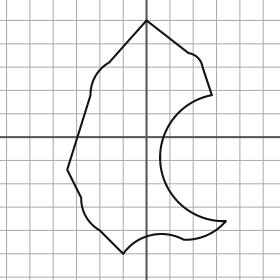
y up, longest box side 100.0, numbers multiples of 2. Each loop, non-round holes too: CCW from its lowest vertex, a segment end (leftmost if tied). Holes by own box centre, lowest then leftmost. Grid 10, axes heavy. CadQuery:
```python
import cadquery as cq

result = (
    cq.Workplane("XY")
    .moveTo(-10.0, -50.0)
    .threePointArc((2.0, -42.0), (16.0, -44.0))
    .threePointArc((26.0, -42.0), (34.0, -36.0))
    .threePointArc((6.0, -12.0), (28.0, 18.0))
    .lineTo(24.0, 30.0)
    .threePointArc((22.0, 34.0), (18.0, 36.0))
    .lineTo(0.0, 50.0)
    .lineTo(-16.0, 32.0)
    .threePointArc((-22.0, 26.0), (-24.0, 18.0))
    .lineTo(-34.0, -14.0)
    .lineTo(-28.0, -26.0)
    .threePointArc((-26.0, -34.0), (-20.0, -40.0))
    .close()
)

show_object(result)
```